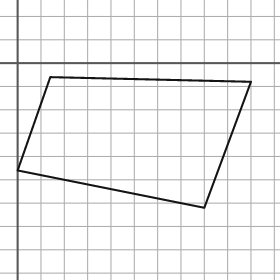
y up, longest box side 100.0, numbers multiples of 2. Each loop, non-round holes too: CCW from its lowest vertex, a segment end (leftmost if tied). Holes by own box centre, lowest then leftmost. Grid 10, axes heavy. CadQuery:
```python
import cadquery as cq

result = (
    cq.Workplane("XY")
    .moveTo(80.0, -62.0)
    .lineTo(100.0, -8.0)
    .lineTo(14.0, -6.0)
    .lineTo(0.0, -46.0)
    .close()
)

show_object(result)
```